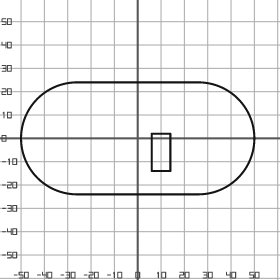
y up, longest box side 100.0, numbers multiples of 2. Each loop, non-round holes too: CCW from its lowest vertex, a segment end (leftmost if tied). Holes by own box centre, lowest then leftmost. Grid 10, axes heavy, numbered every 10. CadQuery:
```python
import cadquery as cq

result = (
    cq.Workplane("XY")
    .moveTo(-26.0, -24.0)
    .lineTo(26.0, -24.0)
    .threePointArc((50.0, 0.0), (26.0, 24.0))
    .lineTo(-26.0, 24.0)
    .threePointArc((-50.0, 0.0), (-26.0, -24.0))
    .close()
    .moveTo(6.0, -14.0)
    .lineTo(14.0, -14.0)
    .lineTo(14.0, 2.0)
    .lineTo(6.0, 2.0)
    .close()
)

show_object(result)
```